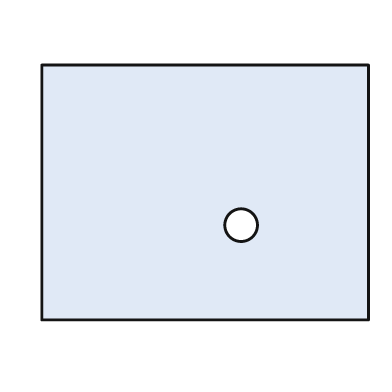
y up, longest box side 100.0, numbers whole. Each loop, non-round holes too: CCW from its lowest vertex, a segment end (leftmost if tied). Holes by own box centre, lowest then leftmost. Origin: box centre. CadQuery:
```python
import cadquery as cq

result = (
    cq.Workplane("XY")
    .moveTo(-50.0, -39.0)
    .lineTo(50.0, -39.0)
    .lineTo(50.0, 39.0)
    .lineTo(-50.0, 39.0)
    .close()
    .moveTo(11.0, -10.0)
    .circle(5.0)
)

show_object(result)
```